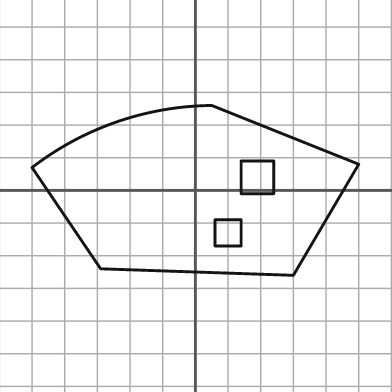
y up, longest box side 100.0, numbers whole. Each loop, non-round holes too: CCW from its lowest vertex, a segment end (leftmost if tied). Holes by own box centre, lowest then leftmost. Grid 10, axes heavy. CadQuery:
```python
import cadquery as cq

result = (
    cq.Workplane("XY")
    .moveTo(30.0, -26.0)
    .lineTo(50.0, 8.0)
    .lineTo(5.0, 26.0)
    .threePointArc((-24.0, 21.0), (-50.0, 7.0))
    .lineTo(-29.0, -24.0)
    .close()
    .moveTo(6.0, -17.0)
    .lineTo(14.0, -17.0)
    .lineTo(14.0, -9.0)
    .lineTo(6.0, -9.0)
    .close()
    .moveTo(14.0, -1.0)
    .lineTo(24.0, -1.0)
    .lineTo(24.0, 9.0)
    .lineTo(14.0, 9.0)
    .close()
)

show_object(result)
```